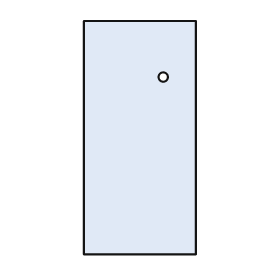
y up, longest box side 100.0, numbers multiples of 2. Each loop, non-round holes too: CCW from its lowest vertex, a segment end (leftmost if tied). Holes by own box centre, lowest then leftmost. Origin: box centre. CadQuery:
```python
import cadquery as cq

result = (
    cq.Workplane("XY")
    .moveTo(-24.0, -50.0)
    .lineTo(24.0, -50.0)
    .lineTo(24.0, 50.0)
    .lineTo(-24.0, 50.0)
    .close()
    .moveTo(10.0, 26.0)
    .circle(2.0)
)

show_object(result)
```